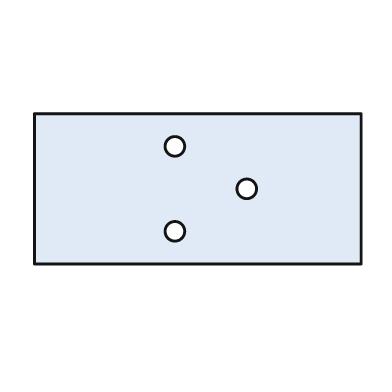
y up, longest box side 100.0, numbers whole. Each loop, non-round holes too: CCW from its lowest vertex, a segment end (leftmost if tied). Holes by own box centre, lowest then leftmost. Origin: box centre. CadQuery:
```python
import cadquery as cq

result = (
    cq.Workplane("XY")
    .moveTo(-50.0, -23.0)
    .lineTo(50.0, -23.0)
    .lineTo(50.0, 23.0)
    .lineTo(-50.0, 23.0)
    .close()
    .moveTo(-7.0, -13.0)
    .circle(3.0)
    .moveTo(15.0, 0.0)
    .circle(3.0)
    .moveTo(-7.0, 13.0)
    .circle(3.0)
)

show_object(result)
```